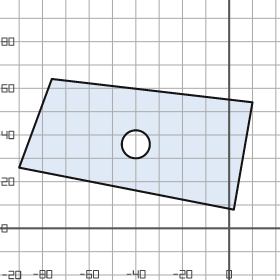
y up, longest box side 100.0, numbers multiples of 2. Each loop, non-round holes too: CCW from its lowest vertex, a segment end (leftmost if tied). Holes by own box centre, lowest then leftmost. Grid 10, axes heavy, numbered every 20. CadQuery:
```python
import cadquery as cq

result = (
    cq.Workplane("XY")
    .moveTo(2.0, 8.0)
    .lineTo(10.0, 54.0)
    .lineTo(-76.0, 64.0)
    .lineTo(-90.0, 26.0)
    .close()
    .moveTo(-40.0, 36.0)
    .circle(6.0)
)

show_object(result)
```